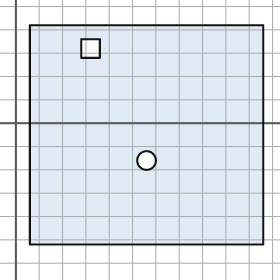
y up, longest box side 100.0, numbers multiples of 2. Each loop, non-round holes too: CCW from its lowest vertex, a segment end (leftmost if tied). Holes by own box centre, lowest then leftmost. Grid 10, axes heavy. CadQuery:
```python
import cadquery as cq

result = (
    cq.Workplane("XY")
    .moveTo(6.0, -52.0)
    .lineTo(106.0, -52.0)
    .lineTo(106.0, 42.0)
    .lineTo(6.0, 42.0)
    .close()
    .moveTo(56.0, -16.0)
    .circle(4.0)
    .moveTo(28.0, 28.0)
    .lineTo(36.0, 28.0)
    .lineTo(36.0, 36.0)
    .lineTo(28.0, 36.0)
    .close()
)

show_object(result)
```